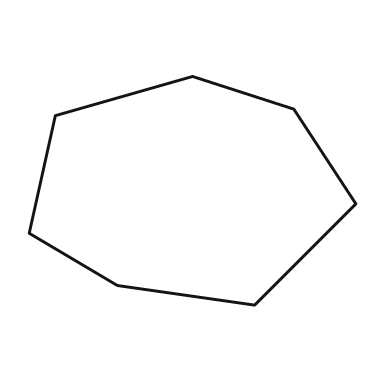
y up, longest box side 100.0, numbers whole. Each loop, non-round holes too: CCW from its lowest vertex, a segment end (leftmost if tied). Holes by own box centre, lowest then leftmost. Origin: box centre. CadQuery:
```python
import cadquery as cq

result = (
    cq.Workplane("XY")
    .moveTo(19.0, -35.0)
    .lineTo(50.0, -4.0)
    .lineTo(31.0, 25.0)
    .lineTo(0.0, 35.0)
    .lineTo(-42.0, 23.0)
    .lineTo(-50.0, -13.0)
    .lineTo(-23.0, -29.0)
    .close()
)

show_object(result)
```